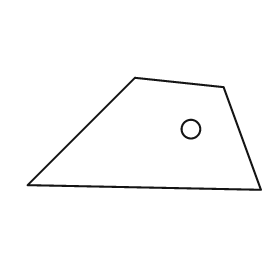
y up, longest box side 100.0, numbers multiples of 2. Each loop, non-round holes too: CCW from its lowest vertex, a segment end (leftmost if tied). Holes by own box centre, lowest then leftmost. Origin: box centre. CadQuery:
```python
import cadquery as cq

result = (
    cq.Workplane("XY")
    .moveTo(50.0, -24.0)
    .lineTo(34.0, 20.0)
    .lineTo(-4.0, 24.0)
    .lineTo(-50.0, -22.0)
    .close()
    .moveTo(20.0, 2.0)
    .circle(4.0)
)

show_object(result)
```